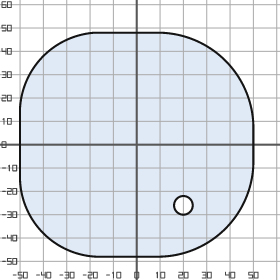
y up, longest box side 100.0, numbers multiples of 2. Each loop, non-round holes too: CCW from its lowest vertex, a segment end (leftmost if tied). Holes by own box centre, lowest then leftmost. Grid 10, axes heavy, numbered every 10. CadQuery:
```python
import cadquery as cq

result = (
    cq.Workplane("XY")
    .moveTo(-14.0, -48.0)
    .lineTo(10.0, -48.0)
    .threePointArc((38.0, -36.0), (50.0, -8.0))
    .lineTo(50.0, 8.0)
    .threePointArc((38.0, 36.0), (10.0, 48.0))
    .lineTo(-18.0, 48.0)
    .threePointArc((-40.0, 38.0), (-50.0, 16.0))
    .lineTo(-50.0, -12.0)
    .threePointArc((-40.0, -38.0), (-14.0, -48.0))
    .close()
    .moveTo(20.0, -26.0)
    .circle(4.0)
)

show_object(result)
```